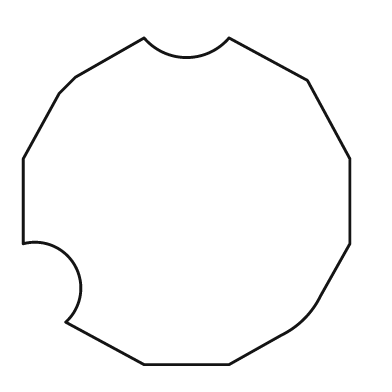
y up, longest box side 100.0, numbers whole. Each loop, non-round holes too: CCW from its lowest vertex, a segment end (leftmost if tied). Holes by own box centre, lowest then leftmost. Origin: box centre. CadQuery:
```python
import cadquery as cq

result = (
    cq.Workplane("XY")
    .moveTo(-13.0, -50.0)
    .lineTo(13.0, -50.0)
    .lineTo(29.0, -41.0)
    .threePointArc((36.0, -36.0), (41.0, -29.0))
    .lineTo(50.0, -13.0)
    .lineTo(50.0, 13.0)
    .lineTo(37.0, 37.0)
    .lineTo(13.0, 50.0)
    .threePointArc((0.0, 44.0), (-13.0, 50.0))
    .lineTo(-34.0, 38.0)
    .lineTo(-39.0, 33.0)
    .lineTo(-50.0, 13.0)
    .lineTo(-50.0, -13.0)
    .threePointArc((-34.0, -20.0), (-37.0, -37.0))
    .close()
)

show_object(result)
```